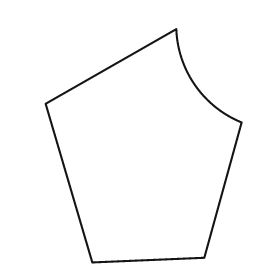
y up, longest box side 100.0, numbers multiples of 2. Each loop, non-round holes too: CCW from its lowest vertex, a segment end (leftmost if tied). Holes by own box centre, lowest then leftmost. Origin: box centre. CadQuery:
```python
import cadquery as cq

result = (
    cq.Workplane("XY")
    .moveTo(-22.0, -50.0)
    .lineTo(26.0, -48.0)
    .lineTo(42.0, 10.0)
    .threePointArc((22.0, 26.0), (14.0, 50.0))
    .lineTo(-42.0, 18.0)
    .close()
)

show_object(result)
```